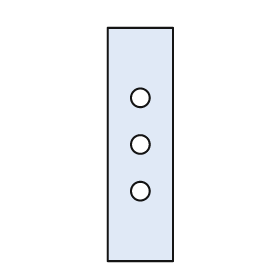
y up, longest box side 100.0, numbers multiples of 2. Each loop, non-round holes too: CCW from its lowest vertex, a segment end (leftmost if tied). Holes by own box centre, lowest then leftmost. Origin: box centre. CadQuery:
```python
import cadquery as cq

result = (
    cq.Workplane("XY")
    .moveTo(-14.0, -50.0)
    .lineTo(14.0, -50.0)
    .lineTo(14.0, 50.0)
    .lineTo(-14.0, 50.0)
    .close()
    .moveTo(0.0, -20.0)
    .circle(4.0)
    .moveTo(0.0, 0.0)
    .circle(4.0)
    .moveTo(0.0, 20.0)
    .circle(4.0)
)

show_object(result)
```